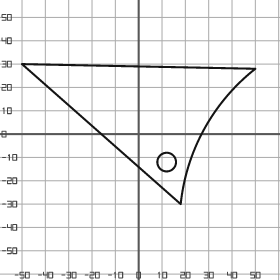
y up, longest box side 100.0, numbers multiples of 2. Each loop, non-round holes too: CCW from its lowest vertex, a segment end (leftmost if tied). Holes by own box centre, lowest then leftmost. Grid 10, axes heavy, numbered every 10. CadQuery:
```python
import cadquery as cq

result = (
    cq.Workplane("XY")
    .moveTo(18.0, -30.0)
    .threePointArc((28.0, 2.0), (50.0, 28.0))
    .lineTo(-50.0, 30.0)
    .close()
    .moveTo(12.0, -12.0)
    .circle(4.0)
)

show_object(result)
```